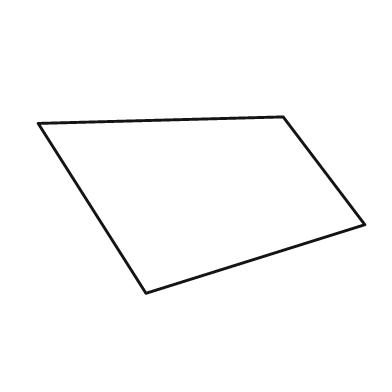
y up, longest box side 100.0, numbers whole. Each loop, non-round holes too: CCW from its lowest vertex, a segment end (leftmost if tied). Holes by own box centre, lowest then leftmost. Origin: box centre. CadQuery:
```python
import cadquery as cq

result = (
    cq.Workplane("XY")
    .moveTo(-17.0, -27.0)
    .lineTo(50.0, -6.0)
    .lineTo(25.0, 27.0)
    .lineTo(-50.0, 25.0)
    .close()
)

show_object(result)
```